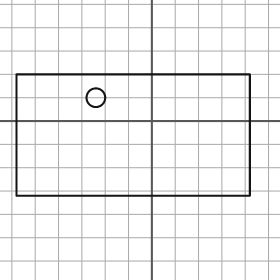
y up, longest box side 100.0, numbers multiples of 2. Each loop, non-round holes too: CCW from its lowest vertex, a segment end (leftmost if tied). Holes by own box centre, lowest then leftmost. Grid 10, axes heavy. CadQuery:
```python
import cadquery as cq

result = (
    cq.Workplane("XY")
    .moveTo(-58.0, -32.0)
    .lineTo(42.0, -32.0)
    .lineTo(42.0, 20.0)
    .lineTo(-58.0, 20.0)
    .close()
    .moveTo(-24.0, 10.0)
    .circle(4.0)
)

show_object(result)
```